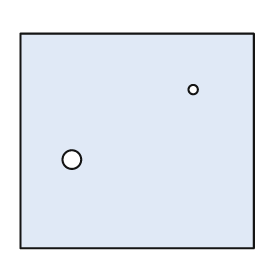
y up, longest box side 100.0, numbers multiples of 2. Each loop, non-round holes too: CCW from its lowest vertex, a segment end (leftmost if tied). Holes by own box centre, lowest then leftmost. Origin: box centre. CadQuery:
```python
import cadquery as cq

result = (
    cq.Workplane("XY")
    .moveTo(-50.0, -46.0)
    .lineTo(50.0, -46.0)
    .lineTo(50.0, 46.0)
    .lineTo(-50.0, 46.0)
    .close()
    .moveTo(-28.0, -8.0)
    .circle(4.0)
    .moveTo(24.0, 22.0)
    .circle(2.0)
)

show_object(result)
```